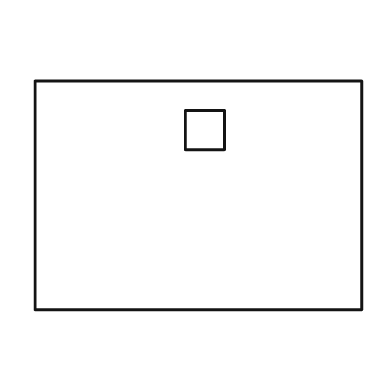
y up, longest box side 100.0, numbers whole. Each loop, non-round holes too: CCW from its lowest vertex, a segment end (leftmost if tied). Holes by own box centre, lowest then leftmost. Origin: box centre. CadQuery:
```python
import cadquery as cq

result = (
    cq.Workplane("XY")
    .moveTo(-50.0, -35.0)
    .lineTo(50.0, -35.0)
    .lineTo(50.0, 35.0)
    .lineTo(-50.0, 35.0)
    .close()
    .moveTo(-4.0, 14.0)
    .lineTo(8.0, 14.0)
    .lineTo(8.0, 26.0)
    .lineTo(-4.0, 26.0)
    .close()
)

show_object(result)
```